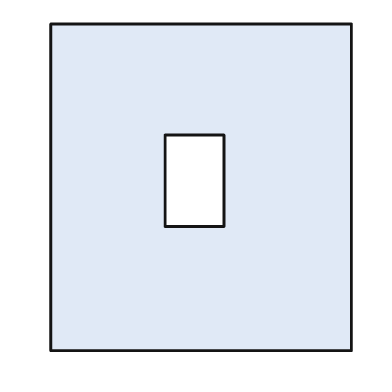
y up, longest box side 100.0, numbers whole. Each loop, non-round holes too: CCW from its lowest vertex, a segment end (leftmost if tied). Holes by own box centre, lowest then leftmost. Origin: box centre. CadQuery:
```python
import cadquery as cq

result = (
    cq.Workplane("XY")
    .moveTo(-46.0, -50.0)
    .lineTo(46.0, -50.0)
    .lineTo(46.0, 50.0)
    .lineTo(-46.0, 50.0)
    .close()
    .moveTo(-11.0, -12.0)
    .lineTo(7.0, -12.0)
    .lineTo(7.0, 16.0)
    .lineTo(-11.0, 16.0)
    .close()
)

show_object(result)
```